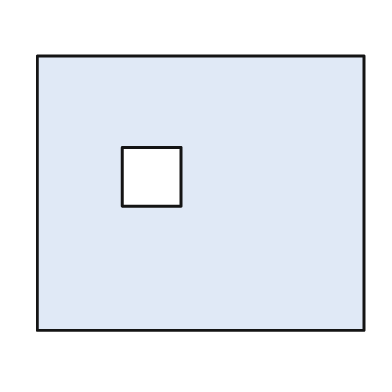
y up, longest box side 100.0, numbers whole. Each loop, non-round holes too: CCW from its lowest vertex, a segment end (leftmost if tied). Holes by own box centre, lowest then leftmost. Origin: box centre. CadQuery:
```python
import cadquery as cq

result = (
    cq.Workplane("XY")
    .moveTo(-50.0, -42.0)
    .lineTo(50.0, -42.0)
    .lineTo(50.0, 42.0)
    .lineTo(-50.0, 42.0)
    .close()
    .moveTo(-24.0, -4.0)
    .lineTo(-6.0, -4.0)
    .lineTo(-6.0, 14.0)
    .lineTo(-24.0, 14.0)
    .close()
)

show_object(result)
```